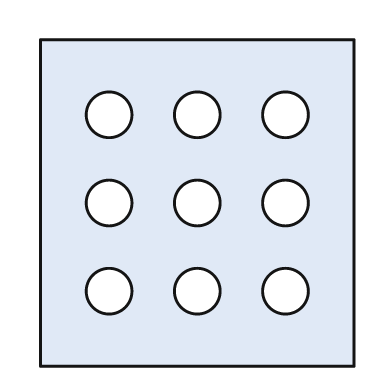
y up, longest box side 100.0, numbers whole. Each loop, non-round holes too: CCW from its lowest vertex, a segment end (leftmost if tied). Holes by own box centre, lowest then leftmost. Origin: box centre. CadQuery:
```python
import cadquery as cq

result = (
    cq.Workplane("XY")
    .moveTo(-48.0, -50.0)
    .lineTo(48.0, -50.0)
    .lineTo(48.0, 50.0)
    .lineTo(-48.0, 50.0)
    .close()
    .moveTo(-27.0, -27.0)
    .circle(7.0)
    .moveTo(0.0, -27.0)
    .circle(7.0)
    .moveTo(27.0, -27.0)
    .circle(7.0)
    .moveTo(-27.0, 0.0)
    .circle(7.0)
    .moveTo(0.0, 0.0)
    .circle(7.0)
    .moveTo(27.0, 0.0)
    .circle(7.0)
    .moveTo(-27.0, 27.0)
    .circle(7.0)
    .moveTo(0.0, 27.0)
    .circle(7.0)
    .moveTo(27.0, 27.0)
    .circle(7.0)
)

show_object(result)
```